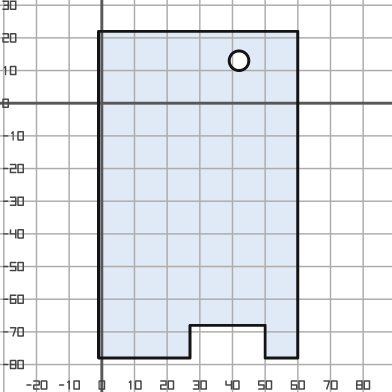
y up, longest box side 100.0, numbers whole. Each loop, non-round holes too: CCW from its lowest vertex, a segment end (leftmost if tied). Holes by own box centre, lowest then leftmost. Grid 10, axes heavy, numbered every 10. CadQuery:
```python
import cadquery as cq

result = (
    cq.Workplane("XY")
    .moveTo(-1.0, -78.0)
    .lineTo(27.0, -78.0)
    .lineTo(27.0, -68.0)
    .lineTo(50.0, -68.0)
    .lineTo(50.0, -78.0)
    .lineTo(60.0, -78.0)
    .lineTo(60.0, 22.0)
    .lineTo(-1.0, 22.0)
    .close()
    .moveTo(42.0, 13.0)
    .circle(3.0)
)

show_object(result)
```